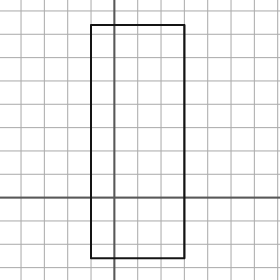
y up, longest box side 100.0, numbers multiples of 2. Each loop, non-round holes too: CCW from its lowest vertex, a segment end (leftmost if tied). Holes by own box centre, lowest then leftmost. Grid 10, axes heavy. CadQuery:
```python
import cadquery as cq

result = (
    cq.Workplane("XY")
    .moveTo(-10.0, -26.0)
    .lineTo(30.0, -26.0)
    .lineTo(30.0, 74.0)
    .lineTo(-10.0, 74.0)
    .close()
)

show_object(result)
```